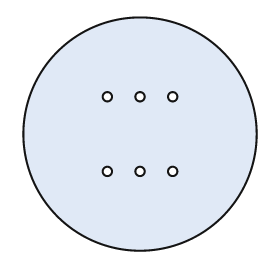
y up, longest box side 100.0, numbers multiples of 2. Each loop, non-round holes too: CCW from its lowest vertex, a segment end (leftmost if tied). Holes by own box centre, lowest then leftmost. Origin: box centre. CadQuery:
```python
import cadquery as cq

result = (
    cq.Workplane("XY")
    .moveTo(0.0, 0.0)
    .circle(50.0)
    .moveTo(-14.0, -16.0)
    .circle(2.0)
    .moveTo(0.0, -16.0)
    .circle(2.0)
    .moveTo(14.0, -16.0)
    .circle(2.0)
    .moveTo(-14.0, 16.0)
    .circle(2.0)
    .moveTo(0.0, 16.0)
    .circle(2.0)
    .moveTo(14.0, 16.0)
    .circle(2.0)
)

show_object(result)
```